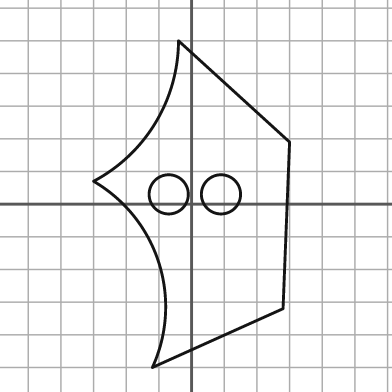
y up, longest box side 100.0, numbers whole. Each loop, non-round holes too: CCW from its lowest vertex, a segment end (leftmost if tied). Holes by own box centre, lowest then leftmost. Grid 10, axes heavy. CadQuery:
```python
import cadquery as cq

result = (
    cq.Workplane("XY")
    .moveTo(-12.0, -50.0)
    .lineTo(28.0, -32.0)
    .lineTo(30.0, 19.0)
    .lineTo(-4.0, 50.0)
    .threePointArc((-11.0, 25.0), (-30.0, 7.0))
    .threePointArc((-10.0, -18.0), (-12.0, -50.0))
    .close()
    .moveTo(-7.0, 3.0)
    .circle(6.0)
    .moveTo(9.0, 3.0)
    .circle(6.0)
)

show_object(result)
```